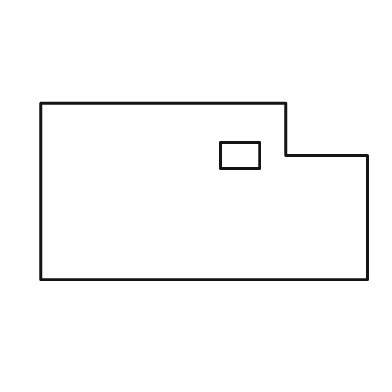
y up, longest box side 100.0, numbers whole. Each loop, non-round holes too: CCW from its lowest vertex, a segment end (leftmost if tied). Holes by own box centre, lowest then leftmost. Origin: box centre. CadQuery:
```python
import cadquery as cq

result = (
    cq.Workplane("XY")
    .moveTo(-50.0, -27.0)
    .lineTo(50.0, -27.0)
    .lineTo(50.0, 11.0)
    .lineTo(25.0, 11.0)
    .lineTo(25.0, 27.0)
    .lineTo(-50.0, 27.0)
    .close()
    .moveTo(5.0, 7.0)
    .lineTo(17.0, 7.0)
    .lineTo(17.0, 15.0)
    .lineTo(5.0, 15.0)
    .close()
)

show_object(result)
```